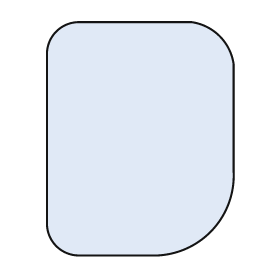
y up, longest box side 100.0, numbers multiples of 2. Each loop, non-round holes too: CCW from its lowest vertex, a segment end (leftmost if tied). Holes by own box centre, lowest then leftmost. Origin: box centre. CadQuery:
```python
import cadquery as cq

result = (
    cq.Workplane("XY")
    .moveTo(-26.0, -50.0)
    .lineTo(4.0, -50.0)
    .threePointArc((30.0, -40.0), (40.0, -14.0))
    .lineTo(40.0, 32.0)
    .threePointArc((34.0, 44.0), (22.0, 50.0))
    .lineTo(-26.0, 50.0)
    .threePointArc((-36.0, 46.0), (-40.0, 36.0))
    .lineTo(-40.0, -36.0)
    .threePointArc((-36.0, -46.0), (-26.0, -50.0))
    .close()
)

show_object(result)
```